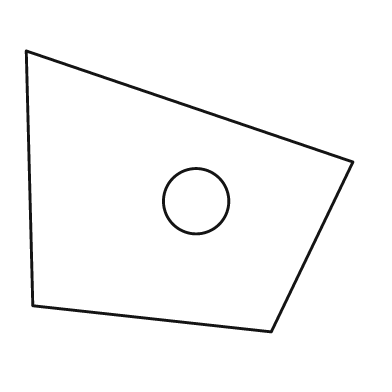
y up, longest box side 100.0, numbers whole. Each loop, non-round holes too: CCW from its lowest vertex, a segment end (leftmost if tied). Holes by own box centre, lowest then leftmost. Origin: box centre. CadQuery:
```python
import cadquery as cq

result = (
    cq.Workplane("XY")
    .moveTo(25.0, -43.0)
    .lineTo(50.0, 9.0)
    .lineTo(-50.0, 43.0)
    .lineTo(-48.0, -35.0)
    .close()
    .moveTo(2.0, -3.0)
    .circle(10.0)
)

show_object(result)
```